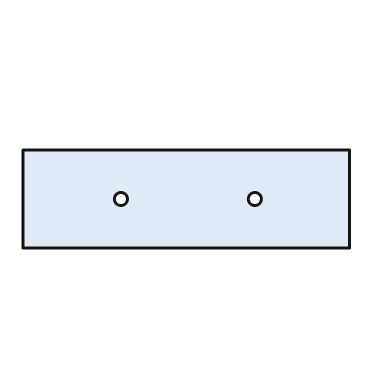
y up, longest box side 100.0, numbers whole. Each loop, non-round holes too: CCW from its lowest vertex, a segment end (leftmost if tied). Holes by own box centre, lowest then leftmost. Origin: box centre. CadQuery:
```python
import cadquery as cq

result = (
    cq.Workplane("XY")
    .moveTo(-50.0, -15.0)
    .lineTo(50.0, -15.0)
    .lineTo(50.0, 15.0)
    .lineTo(-50.0, 15.0)
    .close()
    .moveTo(-20.0, 0.0)
    .circle(2.0)
    .moveTo(21.0, 0.0)
    .circle(2.0)
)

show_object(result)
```